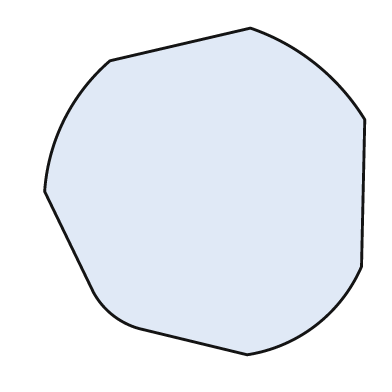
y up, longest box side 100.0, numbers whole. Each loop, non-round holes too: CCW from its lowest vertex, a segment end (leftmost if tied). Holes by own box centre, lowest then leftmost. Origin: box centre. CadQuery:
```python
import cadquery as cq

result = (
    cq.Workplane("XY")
    .moveTo(13.0, -50.0)
    .threePointArc((34.0, -41.0), (48.0, -23.0))
    .lineTo(49.0, 22.0)
    .threePointArc((34.0, 39.0), (14.0, 50.0))
    .lineTo(-29.0, 40.0)
    .threePointArc((-43.0, 22.0), (-49.0, 0.0))
    .lineTo(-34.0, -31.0)
    .threePointArc((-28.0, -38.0), (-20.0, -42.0))
    .close()
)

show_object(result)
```